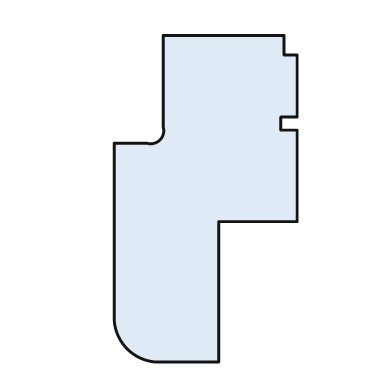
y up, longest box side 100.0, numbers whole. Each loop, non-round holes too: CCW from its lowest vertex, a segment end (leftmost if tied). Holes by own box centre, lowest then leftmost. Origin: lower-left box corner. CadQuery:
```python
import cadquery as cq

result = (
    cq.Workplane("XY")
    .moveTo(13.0, 0.0)
    .lineTo(32.0, 0.0)
    .lineTo(32.0, 43.0)
    .lineTo(56.0, 43.0)
    .lineTo(56.0, 71.0)
    .lineTo(51.0, 71.0)
    .lineTo(51.0, 75.0)
    .lineTo(56.0, 75.0)
    .lineTo(56.0, 94.0)
    .lineTo(52.0, 94.0)
    .lineTo(52.0, 100.0)
    .lineTo(15.0, 100.0)
    .lineTo(15.0, 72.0)
    .threePointArc((14.0, 68.0), (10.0, 67.0))
    .lineTo(0.0, 67.0)
    .lineTo(0.0, 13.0)
    .threePointArc((4.0, 4.0), (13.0, 0.0))
    .close()
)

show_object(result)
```